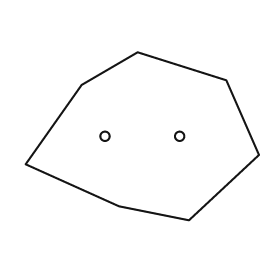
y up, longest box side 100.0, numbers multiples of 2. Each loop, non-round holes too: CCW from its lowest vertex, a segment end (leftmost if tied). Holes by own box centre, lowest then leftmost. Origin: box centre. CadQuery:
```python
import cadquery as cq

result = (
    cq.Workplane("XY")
    .moveTo(20.0, -36.0)
    .lineTo(50.0, -8.0)
    .lineTo(36.0, 24.0)
    .lineTo(-2.0, 36.0)
    .lineTo(-26.0, 22.0)
    .lineTo(-50.0, -12.0)
    .lineTo(-10.0, -30.0)
    .close()
    .moveTo(-16.0, 0.0)
    .circle(2.0)
    .moveTo(16.0, 0.0)
    .circle(2.0)
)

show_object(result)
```